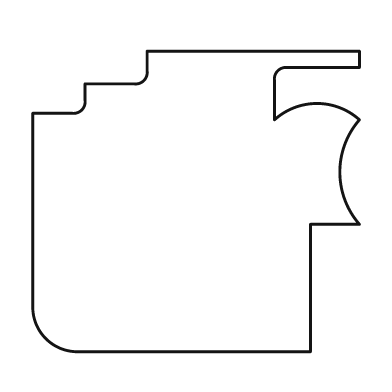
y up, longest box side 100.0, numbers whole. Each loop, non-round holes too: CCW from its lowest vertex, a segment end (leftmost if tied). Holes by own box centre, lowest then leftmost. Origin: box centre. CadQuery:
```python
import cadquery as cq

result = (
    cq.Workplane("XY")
    .moveTo(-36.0, -46.0)
    .lineTo(35.0, -46.0)
    .lineTo(35.0, -7.0)
    .lineTo(50.0, -7.0)
    .threePointArc((44.0, 9.0), (50.0, 25.0))
    .threePointArc((37.0, 30.0), (24.0, 25.0))
    .lineTo(24.0, 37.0)
    .threePointArc((25.0, 40.0), (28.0, 41.0))
    .lineTo(50.0, 41.0)
    .lineTo(50.0, 46.0)
    .lineTo(-15.0, 46.0)
    .lineTo(-15.0, 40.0)
    .threePointArc((-16.0, 37.0), (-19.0, 36.0))
    .lineTo(-34.0, 36.0)
    .lineTo(-34.0, 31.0)
    .threePointArc((-35.0, 28.0), (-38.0, 27.0))
    .lineTo(-50.0, 27.0)
    .lineTo(-50.0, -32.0)
    .threePointArc((-46.0, -42.0), (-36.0, -46.0))
    .close()
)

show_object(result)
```